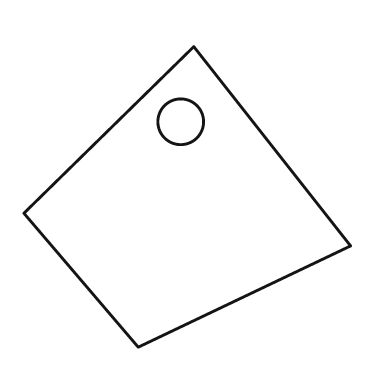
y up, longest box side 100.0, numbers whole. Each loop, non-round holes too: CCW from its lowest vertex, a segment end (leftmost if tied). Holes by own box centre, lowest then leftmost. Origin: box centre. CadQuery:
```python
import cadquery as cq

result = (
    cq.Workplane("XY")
    .moveTo(-15.0, -46.0)
    .lineTo(50.0, -15.0)
    .lineTo(2.0, 46.0)
    .lineTo(-50.0, -5.0)
    .close()
    .moveTo(-2.0, 23.0)
    .circle(7.0)
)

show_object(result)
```